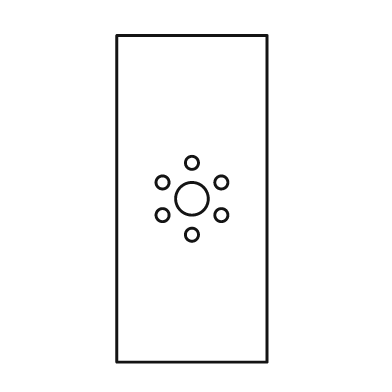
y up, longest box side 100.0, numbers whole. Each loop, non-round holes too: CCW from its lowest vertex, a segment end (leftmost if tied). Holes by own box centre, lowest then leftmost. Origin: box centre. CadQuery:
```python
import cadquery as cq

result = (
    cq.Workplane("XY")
    .moveTo(-23.0, -50.0)
    .lineTo(23.0, -50.0)
    .lineTo(23.0, 50.0)
    .lineTo(-23.0, 50.0)
    .close()
    .moveTo(0.0, -11.0)
    .circle(2.0)
    .moveTo(-9.0, -5.0)
    .circle(2.0)
    .moveTo(9.0, -5.0)
    .circle(2.0)
    .moveTo(0.0, 0.0)
    .circle(5.0)
    .moveTo(-9.0, 5.0)
    .circle(2.0)
    .moveTo(9.0, 5.0)
    .circle(2.0)
    .moveTo(0.0, 11.0)
    .circle(2.0)
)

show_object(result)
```